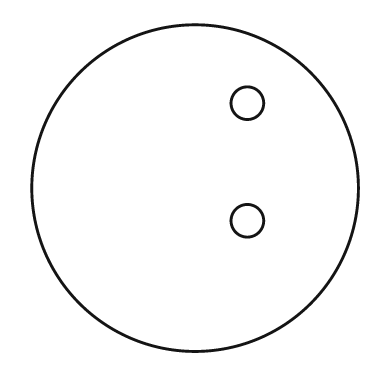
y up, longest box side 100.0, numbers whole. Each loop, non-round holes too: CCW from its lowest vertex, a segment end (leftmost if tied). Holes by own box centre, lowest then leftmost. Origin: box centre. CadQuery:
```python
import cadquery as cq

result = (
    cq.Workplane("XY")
    .moveTo(0.0, 0.0)
    .circle(50.0)
    .moveTo(16.0, -10.0)
    .circle(5.0)
    .moveTo(16.0, 26.0)
    .circle(5.0)
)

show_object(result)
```